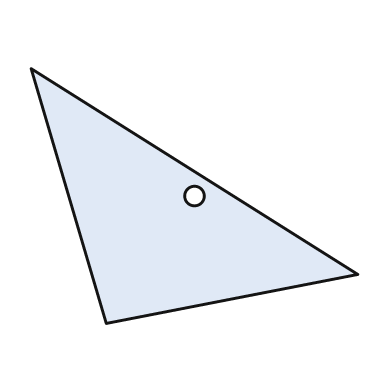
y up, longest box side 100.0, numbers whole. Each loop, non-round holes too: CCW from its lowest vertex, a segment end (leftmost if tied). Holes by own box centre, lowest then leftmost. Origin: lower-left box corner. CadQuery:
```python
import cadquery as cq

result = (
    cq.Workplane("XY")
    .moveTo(23.0, 0.0)
    .lineTo(100.0, 15.0)
    .lineTo(0.0, 78.0)
    .close()
    .moveTo(50.0, 39.0)
    .circle(3.0)
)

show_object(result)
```